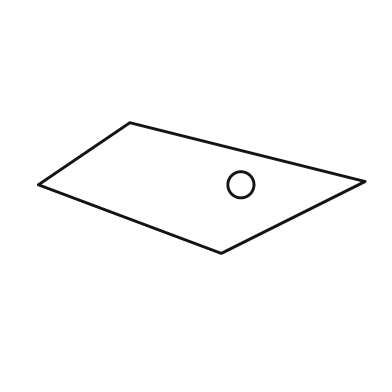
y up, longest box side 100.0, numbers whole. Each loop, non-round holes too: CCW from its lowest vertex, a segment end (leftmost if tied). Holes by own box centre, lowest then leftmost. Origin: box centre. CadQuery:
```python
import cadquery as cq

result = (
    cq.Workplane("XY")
    .moveTo(6.0, -20.0)
    .lineTo(50.0, 2.0)
    .lineTo(-22.0, 20.0)
    .lineTo(-50.0, 1.0)
    .close()
    .moveTo(12.0, 1.0)
    .circle(4.0)
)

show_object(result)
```